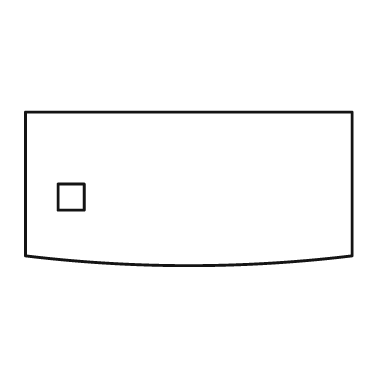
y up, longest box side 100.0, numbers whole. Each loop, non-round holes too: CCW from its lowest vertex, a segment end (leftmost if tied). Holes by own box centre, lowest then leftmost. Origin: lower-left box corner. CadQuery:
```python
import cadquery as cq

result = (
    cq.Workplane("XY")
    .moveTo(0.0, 3.0)
    .threePointArc((50.0, 0.0), (100.0, 3.0))
    .lineTo(100.0, 47.0)
    .lineTo(0.0, 47.0)
    .close()
    .moveTo(10.0, 17.0)
    .lineTo(18.0, 17.0)
    .lineTo(18.0, 25.0)
    .lineTo(10.0, 25.0)
    .close()
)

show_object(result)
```